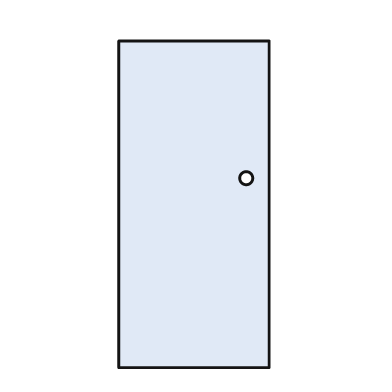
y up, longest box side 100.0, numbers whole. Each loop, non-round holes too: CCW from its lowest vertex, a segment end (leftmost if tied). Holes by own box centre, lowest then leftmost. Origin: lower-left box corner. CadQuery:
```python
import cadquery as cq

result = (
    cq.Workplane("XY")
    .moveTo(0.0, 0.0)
    .lineTo(46.0, 0.0)
    .lineTo(46.0, 100.0)
    .lineTo(0.0, 100.0)
    .close()
    .moveTo(39.0, 58.0)
    .circle(2.0)
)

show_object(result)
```